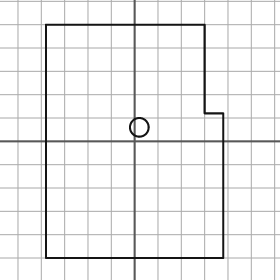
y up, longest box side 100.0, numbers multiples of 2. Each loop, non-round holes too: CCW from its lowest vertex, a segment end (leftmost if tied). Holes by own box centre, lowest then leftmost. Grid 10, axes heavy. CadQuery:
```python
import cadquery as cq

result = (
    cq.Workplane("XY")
    .moveTo(-38.0, -50.0)
    .lineTo(38.0, -50.0)
    .lineTo(38.0, 12.0)
    .lineTo(30.0, 12.0)
    .lineTo(30.0, 50.0)
    .lineTo(-38.0, 50.0)
    .close()
    .moveTo(2.0, 6.0)
    .circle(4.0)
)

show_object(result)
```